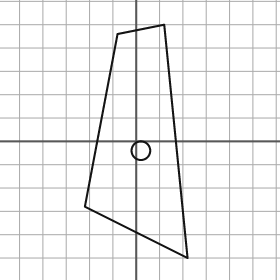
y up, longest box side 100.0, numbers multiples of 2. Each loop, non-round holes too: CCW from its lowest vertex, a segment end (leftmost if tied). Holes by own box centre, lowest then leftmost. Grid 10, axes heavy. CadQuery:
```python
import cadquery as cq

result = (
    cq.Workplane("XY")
    .moveTo(22.0, -50.0)
    .lineTo(12.0, 50.0)
    .lineTo(-8.0, 46.0)
    .lineTo(-22.0, -28.0)
    .close()
    .moveTo(2.0, -4.0)
    .circle(4.0)
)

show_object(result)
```